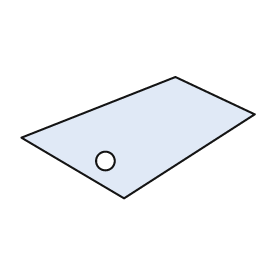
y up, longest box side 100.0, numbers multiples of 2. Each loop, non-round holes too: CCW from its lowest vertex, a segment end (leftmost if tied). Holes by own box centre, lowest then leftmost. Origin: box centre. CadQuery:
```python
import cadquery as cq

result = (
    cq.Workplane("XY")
    .moveTo(-6.0, -26.0)
    .lineTo(50.0, 10.0)
    .lineTo(16.0, 26.0)
    .lineTo(-50.0, 0.0)
    .close()
    .moveTo(-14.0, -10.0)
    .circle(4.0)
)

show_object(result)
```